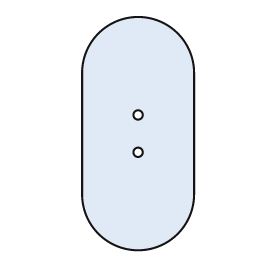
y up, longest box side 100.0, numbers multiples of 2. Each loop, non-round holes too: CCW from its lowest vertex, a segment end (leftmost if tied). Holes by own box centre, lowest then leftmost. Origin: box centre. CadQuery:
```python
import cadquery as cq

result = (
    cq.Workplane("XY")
    .moveTo(-24.0, -26.0)
    .threePointArc((0.0, -50.0), (24.0, -26.0))
    .lineTo(24.0, 26.0)
    .threePointArc((0.0, 50.0), (-24.0, 26.0))
    .close()
    .moveTo(0.0, -8.0)
    .circle(2.0)
    .moveTo(0.0, 8.0)
    .circle(2.0)
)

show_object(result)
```